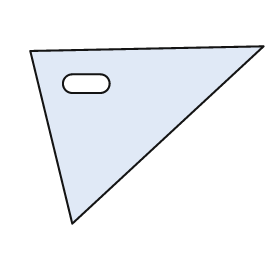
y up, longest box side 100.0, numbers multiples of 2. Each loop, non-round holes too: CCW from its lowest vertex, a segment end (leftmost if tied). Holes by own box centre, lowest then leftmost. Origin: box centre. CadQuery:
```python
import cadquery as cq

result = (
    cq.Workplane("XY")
    .moveTo(-32.0, -38.0)
    .lineTo(50.0, 38.0)
    .lineTo(-50.0, 36.0)
    .close()
    .moveTo(-32.0, 18.0)
    .lineTo(-20.0, 18.0)
    .threePointArc((-16.0, 22.0), (-20.0, 26.0))
    .lineTo(-32.0, 26.0)
    .threePointArc((-36.0, 22.0), (-32.0, 18.0))
    .close()
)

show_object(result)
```